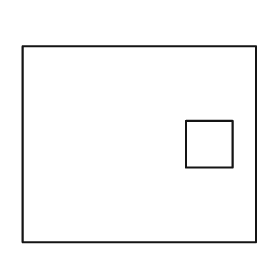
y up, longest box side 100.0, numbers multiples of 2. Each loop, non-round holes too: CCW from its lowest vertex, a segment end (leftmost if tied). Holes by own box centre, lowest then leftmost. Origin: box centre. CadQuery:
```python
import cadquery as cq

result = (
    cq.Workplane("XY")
    .moveTo(-50.0, -42.0)
    .lineTo(50.0, -42.0)
    .lineTo(50.0, 42.0)
    .lineTo(-50.0, 42.0)
    .close()
    .moveTo(20.0, -10.0)
    .lineTo(40.0, -10.0)
    .lineTo(40.0, 10.0)
    .lineTo(20.0, 10.0)
    .close()
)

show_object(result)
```